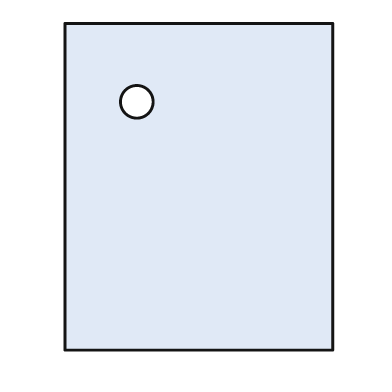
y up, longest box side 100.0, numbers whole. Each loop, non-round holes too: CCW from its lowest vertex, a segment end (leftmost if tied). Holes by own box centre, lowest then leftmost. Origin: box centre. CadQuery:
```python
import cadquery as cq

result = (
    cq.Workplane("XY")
    .moveTo(-41.0, -50.0)
    .lineTo(41.0, -50.0)
    .lineTo(41.0, 50.0)
    .lineTo(-41.0, 50.0)
    .close()
    .moveTo(-19.0, 26.0)
    .circle(5.0)
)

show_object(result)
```